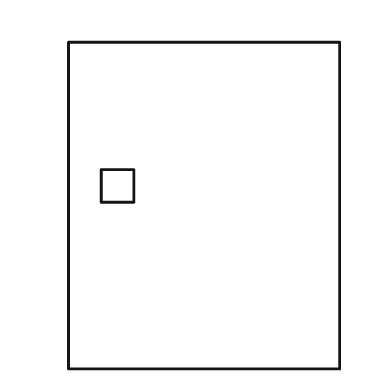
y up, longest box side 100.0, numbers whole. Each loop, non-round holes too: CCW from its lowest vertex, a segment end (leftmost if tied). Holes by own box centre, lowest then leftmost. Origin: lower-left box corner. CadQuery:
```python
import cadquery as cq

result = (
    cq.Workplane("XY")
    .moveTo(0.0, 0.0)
    .lineTo(83.0, 0.0)
    .lineTo(83.0, 100.0)
    .lineTo(0.0, 100.0)
    .close()
    .moveTo(10.0, 51.0)
    .lineTo(20.0, 51.0)
    .lineTo(20.0, 61.0)
    .lineTo(10.0, 61.0)
    .close()
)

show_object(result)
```